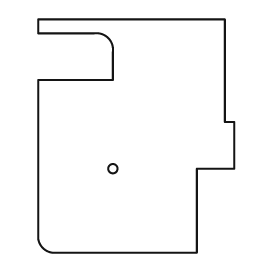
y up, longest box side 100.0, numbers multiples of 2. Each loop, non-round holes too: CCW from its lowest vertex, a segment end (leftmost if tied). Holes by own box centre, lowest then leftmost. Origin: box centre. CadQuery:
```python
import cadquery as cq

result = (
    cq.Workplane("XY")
    .moveTo(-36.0, -50.0)
    .lineTo(26.0, -50.0)
    .lineTo(26.0, -14.0)
    .lineTo(42.0, -14.0)
    .lineTo(42.0, 6.0)
    .lineTo(38.0, 6.0)
    .lineTo(38.0, 50.0)
    .lineTo(-42.0, 50.0)
    .lineTo(-42.0, 44.0)
    .lineTo(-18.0, 44.0)
    .threePointArc((-12.0, 42.0), (-10.0, 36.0))
    .lineTo(-10.0, 24.0)
    .lineTo(-42.0, 24.0)
    .lineTo(-42.0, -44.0)
    .threePointArc((-40.0, -48.0), (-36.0, -50.0))
    .close()
    .moveTo(-10.0, -14.0)
    .circle(2.0)
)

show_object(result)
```